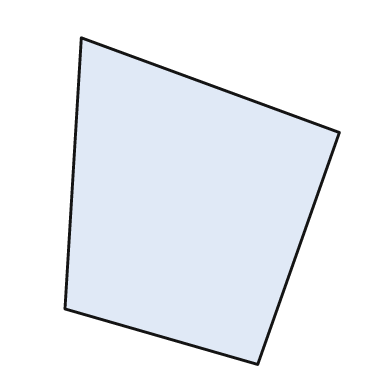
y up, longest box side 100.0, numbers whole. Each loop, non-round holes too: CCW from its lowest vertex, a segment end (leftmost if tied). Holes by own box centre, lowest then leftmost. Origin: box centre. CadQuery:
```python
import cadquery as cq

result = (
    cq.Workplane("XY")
    .moveTo(17.0, -50.0)
    .lineTo(42.0, 21.0)
    .lineTo(-37.0, 50.0)
    .lineTo(-42.0, -33.0)
    .close()
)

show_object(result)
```